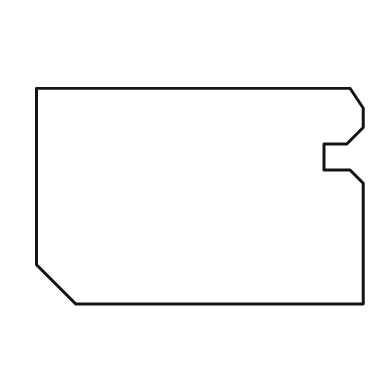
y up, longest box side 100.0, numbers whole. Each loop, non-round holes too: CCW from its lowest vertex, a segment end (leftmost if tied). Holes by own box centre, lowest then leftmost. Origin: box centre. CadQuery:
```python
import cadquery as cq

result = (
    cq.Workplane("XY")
    .moveTo(-38.0, -33.0)
    .lineTo(50.0, -33.0)
    .lineTo(50.0, 4.0)
    .lineTo(46.0, 8.0)
    .lineTo(38.0, 8.0)
    .lineTo(38.0, 16.0)
    .lineTo(45.0, 16.0)
    .lineTo(50.0, 21.0)
    .lineTo(50.0, 27.0)
    .lineTo(46.0, 33.0)
    .lineTo(-50.0, 33.0)
    .lineTo(-50.0, -21.0)
    .close()
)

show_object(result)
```